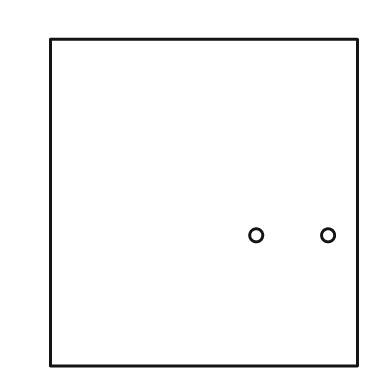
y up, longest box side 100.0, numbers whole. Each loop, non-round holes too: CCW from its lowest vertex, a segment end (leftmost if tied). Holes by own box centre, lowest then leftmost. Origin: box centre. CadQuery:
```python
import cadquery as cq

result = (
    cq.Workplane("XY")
    .moveTo(-47.0, -50.0)
    .lineTo(47.0, -50.0)
    .lineTo(47.0, 50.0)
    .lineTo(-47.0, 50.0)
    .close()
    .moveTo(16.0, -10.0)
    .circle(2.0)
    .moveTo(38.0, -10.0)
    .circle(2.0)
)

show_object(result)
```